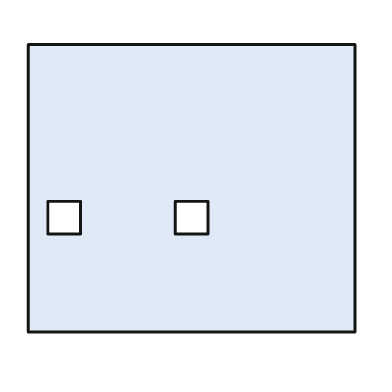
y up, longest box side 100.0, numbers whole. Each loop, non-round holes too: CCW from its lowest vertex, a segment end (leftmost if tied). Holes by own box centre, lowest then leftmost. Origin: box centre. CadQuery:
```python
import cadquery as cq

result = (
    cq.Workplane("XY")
    .moveTo(-50.0, -44.0)
    .lineTo(50.0, -44.0)
    .lineTo(50.0, 44.0)
    .lineTo(-50.0, 44.0)
    .close()
    .moveTo(-44.0, -14.0)
    .lineTo(-34.0, -14.0)
    .lineTo(-34.0, -4.0)
    .lineTo(-44.0, -4.0)
    .close()
    .moveTo(-5.0, -14.0)
    .lineTo(5.0, -14.0)
    .lineTo(5.0, -4.0)
    .lineTo(-5.0, -4.0)
    .close()
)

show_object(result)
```